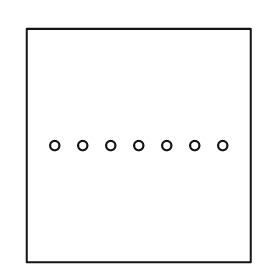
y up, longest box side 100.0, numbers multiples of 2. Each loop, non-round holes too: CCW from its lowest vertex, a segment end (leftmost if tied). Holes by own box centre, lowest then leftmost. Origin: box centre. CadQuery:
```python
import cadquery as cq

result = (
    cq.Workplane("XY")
    .moveTo(-48.0, -50.0)
    .lineTo(48.0, -50.0)
    .lineTo(48.0, 50.0)
    .lineTo(-48.0, 50.0)
    .close()
    .moveTo(-36.0, 0.0)
    .circle(2.0)
    .moveTo(-24.0, 0.0)
    .circle(2.0)
    .moveTo(-12.0, 0.0)
    .circle(2.0)
    .moveTo(0.0, 0.0)
    .circle(2.0)
    .moveTo(12.0, 0.0)
    .circle(2.0)
    .moveTo(24.0, 0.0)
    .circle(2.0)
    .moveTo(36.0, 0.0)
    .circle(2.0)
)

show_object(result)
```